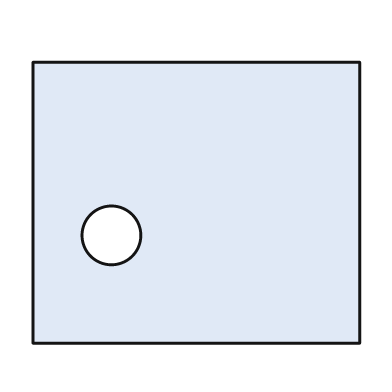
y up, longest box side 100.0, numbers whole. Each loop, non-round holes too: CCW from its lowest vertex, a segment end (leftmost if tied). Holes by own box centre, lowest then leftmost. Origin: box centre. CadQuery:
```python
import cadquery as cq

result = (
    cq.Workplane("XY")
    .moveTo(-50.0, -43.0)
    .lineTo(50.0, -43.0)
    .lineTo(50.0, 43.0)
    .lineTo(-50.0, 43.0)
    .close()
    .moveTo(-26.0, -10.0)
    .circle(9.0)
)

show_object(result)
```